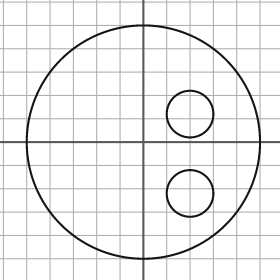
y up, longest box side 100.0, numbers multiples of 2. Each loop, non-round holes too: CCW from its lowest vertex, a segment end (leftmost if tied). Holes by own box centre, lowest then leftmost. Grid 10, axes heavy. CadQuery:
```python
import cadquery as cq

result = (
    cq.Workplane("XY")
    .moveTo(0.0, 0.0)
    .circle(50.0)
    .moveTo(20.0, -22.0)
    .circle(10.0)
    .moveTo(20.0, 12.0)
    .circle(10.0)
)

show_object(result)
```